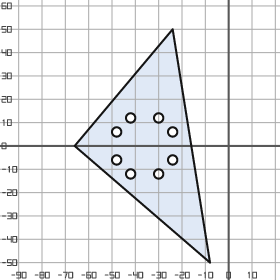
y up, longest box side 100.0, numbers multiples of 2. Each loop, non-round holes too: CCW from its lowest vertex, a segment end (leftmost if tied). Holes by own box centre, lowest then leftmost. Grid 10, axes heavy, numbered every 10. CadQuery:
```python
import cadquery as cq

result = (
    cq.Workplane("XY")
    .moveTo(-8.0, -50.0)
    .lineTo(-24.0, 50.0)
    .lineTo(-66.0, 0.0)
    .close()
    .moveTo(-42.0, -12.0)
    .circle(2.0)
    .moveTo(-30.0, -12.0)
    .circle(2.0)
    .moveTo(-48.0, -6.0)
    .circle(2.0)
    .moveTo(-24.0, -6.0)
    .circle(2.0)
    .moveTo(-48.0, 6.0)
    .circle(2.0)
    .moveTo(-24.0, 6.0)
    .circle(2.0)
    .moveTo(-42.0, 12.0)
    .circle(2.0)
    .moveTo(-30.0, 12.0)
    .circle(2.0)
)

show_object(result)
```